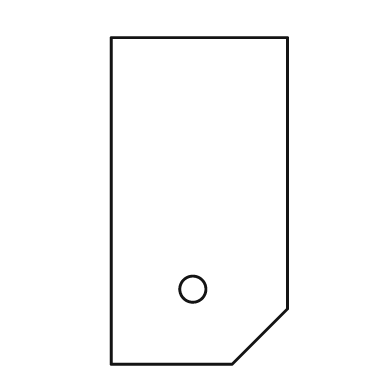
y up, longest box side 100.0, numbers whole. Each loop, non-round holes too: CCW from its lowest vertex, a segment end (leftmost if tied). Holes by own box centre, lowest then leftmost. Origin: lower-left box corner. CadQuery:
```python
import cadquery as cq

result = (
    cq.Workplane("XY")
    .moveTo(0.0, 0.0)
    .lineTo(37.0, 0.0)
    .lineTo(54.0, 17.0)
    .lineTo(54.0, 100.0)
    .lineTo(0.0, 100.0)
    .close()
    .moveTo(25.0, 23.0)
    .circle(4.0)
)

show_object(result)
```